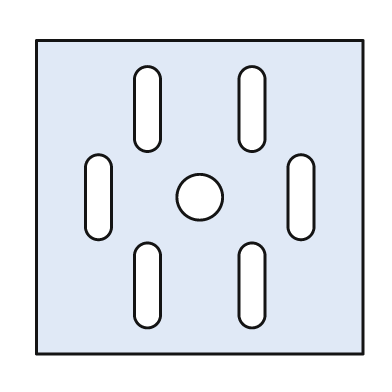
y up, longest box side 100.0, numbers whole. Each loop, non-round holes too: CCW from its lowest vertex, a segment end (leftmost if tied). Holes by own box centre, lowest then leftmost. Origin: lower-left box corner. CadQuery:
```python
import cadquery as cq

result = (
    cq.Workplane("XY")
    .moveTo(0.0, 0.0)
    .lineTo(100.0, 0.0)
    .lineTo(100.0, 96.0)
    .lineTo(0.0, 96.0)
    .close()
    .moveTo(30.0, 12.0)
    .threePointArc((34.0, 8.0), (38.0, 12.0))
    .lineTo(38.0, 30.0)
    .threePointArc((34.0, 34.0), (30.0, 30.0))
    .close()
    .moveTo(62.0, 12.0)
    .threePointArc((66.0, 8.0), (70.0, 12.0))
    .lineTo(70.0, 30.0)
    .threePointArc((66.0, 34.0), (62.0, 30.0))
    .close()
    .moveTo(15.0, 39.0)
    .threePointArc((19.0, 35.0), (23.0, 39.0))
    .lineTo(23.0, 57.0)
    .threePointArc((19.0, 61.0), (15.0, 57.0))
    .close()
    .moveTo(50.0, 48.0)
    .circle(7.0)
    .moveTo(77.0, 39.0)
    .threePointArc((81.0, 35.0), (85.0, 39.0))
    .lineTo(85.0, 57.0)
    .threePointArc((81.0, 61.0), (77.0, 57.0))
    .close()
    .moveTo(30.0, 66.0)
    .threePointArc((34.0, 62.0), (38.0, 66.0))
    .lineTo(38.0, 84.0)
    .threePointArc((34.0, 88.0), (30.0, 84.0))
    .close()
    .moveTo(62.0, 66.0)
    .threePointArc((66.0, 62.0), (70.0, 66.0))
    .lineTo(70.0, 84.0)
    .threePointArc((66.0, 88.0), (62.0, 84.0))
    .close()
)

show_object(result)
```